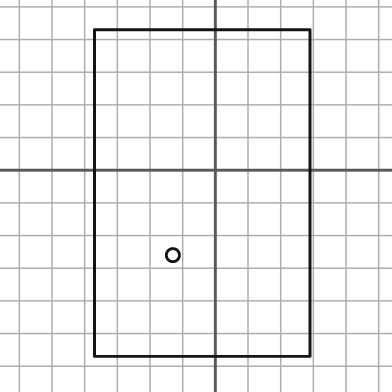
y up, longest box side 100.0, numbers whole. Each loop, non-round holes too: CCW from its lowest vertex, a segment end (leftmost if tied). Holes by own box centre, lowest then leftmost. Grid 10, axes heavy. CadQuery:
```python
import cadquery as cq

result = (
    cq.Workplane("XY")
    .moveTo(-37.0, -57.0)
    .lineTo(29.0, -57.0)
    .lineTo(29.0, 43.0)
    .lineTo(-37.0, 43.0)
    .close()
    .moveTo(-13.0, -26.0)
    .circle(2.0)
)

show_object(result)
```